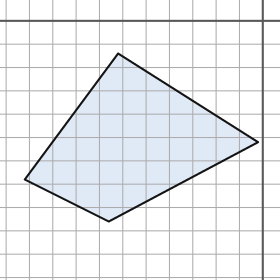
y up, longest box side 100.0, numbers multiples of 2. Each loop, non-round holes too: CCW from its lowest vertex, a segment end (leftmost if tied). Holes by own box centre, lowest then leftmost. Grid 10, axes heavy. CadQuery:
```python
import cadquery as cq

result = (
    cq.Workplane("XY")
    .moveTo(-66.0, -86.0)
    .lineTo(-2.0, -52.0)
    .lineTo(-62.0, -14.0)
    .lineTo(-102.0, -68.0)
    .close()
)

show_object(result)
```